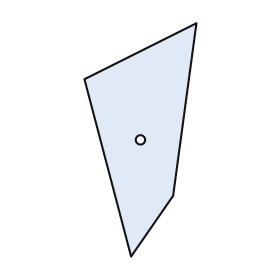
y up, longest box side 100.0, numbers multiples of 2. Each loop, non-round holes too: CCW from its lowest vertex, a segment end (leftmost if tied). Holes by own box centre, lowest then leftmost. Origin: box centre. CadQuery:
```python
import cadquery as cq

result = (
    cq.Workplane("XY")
    .moveTo(-4.0, -50.0)
    .lineTo(14.0, -24.0)
    .lineTo(24.0, 50.0)
    .lineTo(-24.0, 26.0)
    .close()
    .moveTo(0.0, 0.0)
    .circle(2.0)
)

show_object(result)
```